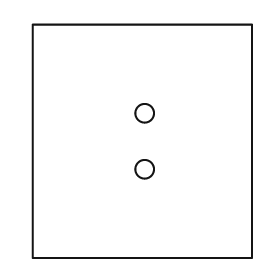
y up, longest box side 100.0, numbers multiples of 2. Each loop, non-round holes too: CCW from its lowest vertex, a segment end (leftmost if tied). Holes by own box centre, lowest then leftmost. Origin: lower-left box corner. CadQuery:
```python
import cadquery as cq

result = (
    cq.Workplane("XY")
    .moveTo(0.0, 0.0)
    .lineTo(94.0, 0.0)
    .lineTo(94.0, 100.0)
    .lineTo(0.0, 100.0)
    .close()
    .moveTo(48.0, 38.0)
    .circle(4.0)
    .moveTo(48.0, 62.0)
    .circle(4.0)
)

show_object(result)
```